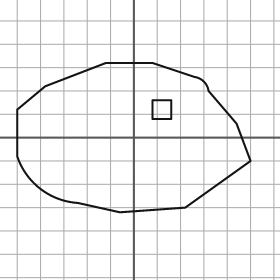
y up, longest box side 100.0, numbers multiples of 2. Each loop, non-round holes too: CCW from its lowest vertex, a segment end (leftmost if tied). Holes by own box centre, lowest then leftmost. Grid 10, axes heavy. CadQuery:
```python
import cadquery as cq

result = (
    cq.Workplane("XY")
    .moveTo(-6.0, -32.0)
    .lineTo(22.0, -30.0)
    .lineTo(50.0, -10.0)
    .lineTo(44.0, 6.0)
    .lineTo(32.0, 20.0)
    .threePointArc((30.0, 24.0), (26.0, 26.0))
    .lineTo(8.0, 32.0)
    .lineTo(-12.0, 32.0)
    .lineTo(-38.0, 22.0)
    .lineTo(-50.0, 12.0)
    .lineTo(-50.0, -8.0)
    .threePointArc((-40.0, -22.0), (-24.0, -28.0))
    .close()
    .moveTo(8.0, 8.0)
    .lineTo(16.0, 8.0)
    .lineTo(16.0, 16.0)
    .lineTo(8.0, 16.0)
    .close()
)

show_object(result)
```